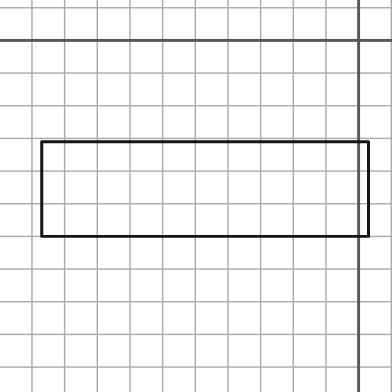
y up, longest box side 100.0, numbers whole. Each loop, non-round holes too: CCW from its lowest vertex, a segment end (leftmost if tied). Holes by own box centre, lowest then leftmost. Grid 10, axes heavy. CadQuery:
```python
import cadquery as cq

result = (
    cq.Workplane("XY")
    .moveTo(-97.0, -60.0)
    .lineTo(3.0, -60.0)
    .lineTo(3.0, -31.0)
    .lineTo(-97.0, -31.0)
    .close()
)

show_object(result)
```